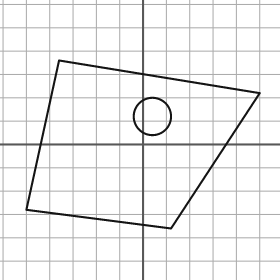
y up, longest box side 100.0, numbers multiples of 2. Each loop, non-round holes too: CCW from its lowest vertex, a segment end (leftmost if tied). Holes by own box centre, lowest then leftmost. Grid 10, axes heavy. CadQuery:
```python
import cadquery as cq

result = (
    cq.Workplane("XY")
    .moveTo(12.0, -36.0)
    .lineTo(50.0, 22.0)
    .lineTo(-36.0, 36.0)
    .lineTo(-50.0, -28.0)
    .close()
    .moveTo(4.0, 12.0)
    .circle(8.0)
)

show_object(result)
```